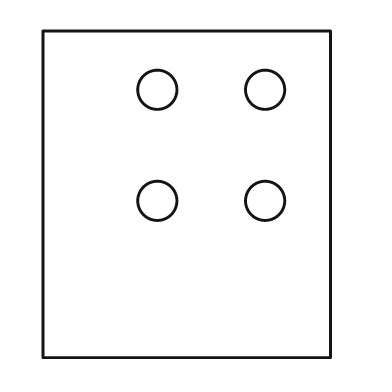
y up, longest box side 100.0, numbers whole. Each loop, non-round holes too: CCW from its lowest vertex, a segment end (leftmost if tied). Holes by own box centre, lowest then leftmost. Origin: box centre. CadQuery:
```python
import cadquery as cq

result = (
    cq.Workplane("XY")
    .moveTo(-44.0, -50.0)
    .lineTo(44.0, -50.0)
    .lineTo(44.0, 50.0)
    .lineTo(-44.0, 50.0)
    .close()
    .moveTo(-9.0, -2.0)
    .circle(6.0)
    .moveTo(24.0, -2.0)
    .circle(6.0)
    .moveTo(-9.0, 32.0)
    .circle(6.0)
    .moveTo(24.0, 32.0)
    .circle(6.0)
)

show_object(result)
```